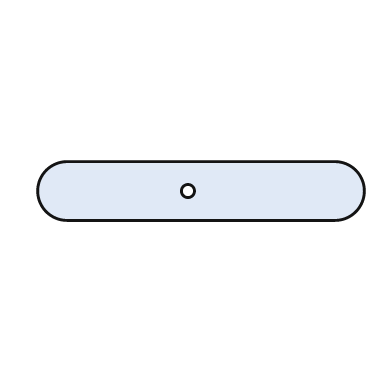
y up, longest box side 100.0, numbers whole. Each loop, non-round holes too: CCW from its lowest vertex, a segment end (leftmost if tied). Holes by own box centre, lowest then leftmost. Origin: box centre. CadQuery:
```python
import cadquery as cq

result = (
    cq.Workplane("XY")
    .moveTo(-41.0, -9.0)
    .lineTo(41.0, -9.0)
    .threePointArc((50.0, 0.0), (41.0, 9.0))
    .lineTo(-41.0, 9.0)
    .threePointArc((-50.0, 0.0), (-41.0, -9.0))
    .close()
    .moveTo(-4.0, 0.0)
    .circle(2.0)
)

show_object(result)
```